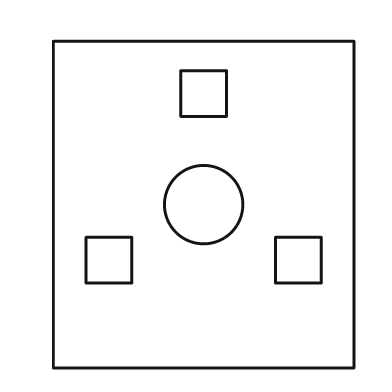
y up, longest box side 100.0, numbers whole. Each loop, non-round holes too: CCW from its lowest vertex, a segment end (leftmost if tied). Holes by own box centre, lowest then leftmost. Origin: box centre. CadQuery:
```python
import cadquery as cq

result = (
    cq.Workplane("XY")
    .moveTo(-46.0, -50.0)
    .lineTo(46.0, -50.0)
    .lineTo(46.0, 50.0)
    .lineTo(-46.0, 50.0)
    .close()
    .moveTo(-36.0, -24.0)
    .lineTo(-22.0, -24.0)
    .lineTo(-22.0, -10.0)
    .lineTo(-36.0, -10.0)
    .close()
    .moveTo(22.0, -24.0)
    .lineTo(36.0, -24.0)
    .lineTo(36.0, -10.0)
    .lineTo(22.0, -10.0)
    .close()
    .moveTo(0.0, 0.0)
    .circle(12.0)
    .moveTo(-7.0, 27.0)
    .lineTo(7.0, 27.0)
    .lineTo(7.0, 41.0)
    .lineTo(-7.0, 41.0)
    .close()
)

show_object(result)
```